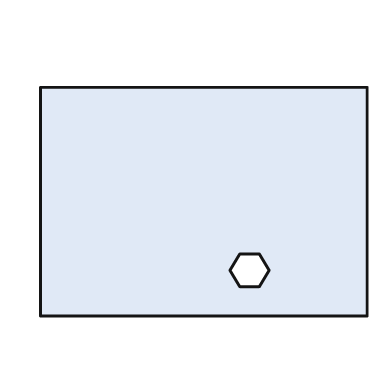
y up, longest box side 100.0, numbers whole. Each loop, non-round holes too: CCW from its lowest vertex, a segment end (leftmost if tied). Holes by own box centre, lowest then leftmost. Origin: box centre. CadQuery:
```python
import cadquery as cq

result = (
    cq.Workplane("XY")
    .moveTo(-50.0, -35.0)
    .lineTo(50.0, -35.0)
    .lineTo(50.0, 35.0)
    .lineTo(-50.0, 35.0)
    .close()
    .moveTo(11.0, -26.0)
    .lineTo(17.0, -26.0)
    .lineTo(20.0, -21.0)
    .lineTo(17.0, -16.0)
    .lineTo(11.0, -16.0)
    .lineTo(8.0, -21.0)
    .close()
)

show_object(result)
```